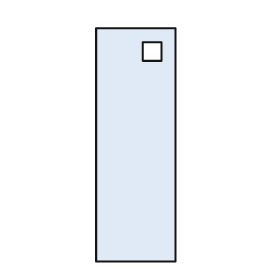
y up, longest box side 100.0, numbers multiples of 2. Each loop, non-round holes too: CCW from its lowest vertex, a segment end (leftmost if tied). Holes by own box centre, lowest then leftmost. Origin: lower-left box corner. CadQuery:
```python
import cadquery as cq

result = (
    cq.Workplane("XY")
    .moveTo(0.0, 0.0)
    .lineTo(34.0, 0.0)
    .lineTo(34.0, 100.0)
    .lineTo(0.0, 100.0)
    .close()
    .moveTo(20.0, 86.0)
    .lineTo(28.0, 86.0)
    .lineTo(28.0, 94.0)
    .lineTo(20.0, 94.0)
    .close()
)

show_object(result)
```